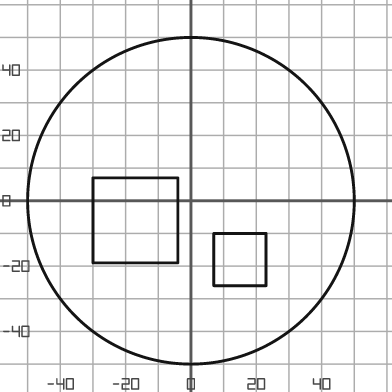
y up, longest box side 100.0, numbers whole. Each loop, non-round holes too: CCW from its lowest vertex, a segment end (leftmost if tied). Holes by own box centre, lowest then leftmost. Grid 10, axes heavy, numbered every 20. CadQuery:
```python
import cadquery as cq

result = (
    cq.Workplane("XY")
    .moveTo(0.0, 0.0)
    .circle(50.0)
    .moveTo(7.0, -26.0)
    .lineTo(23.0, -26.0)
    .lineTo(23.0, -10.0)
    .lineTo(7.0, -10.0)
    .close()
    .moveTo(-30.0, -19.0)
    .lineTo(-4.0, -19.0)
    .lineTo(-4.0, 7.0)
    .lineTo(-30.0, 7.0)
    .close()
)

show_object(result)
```